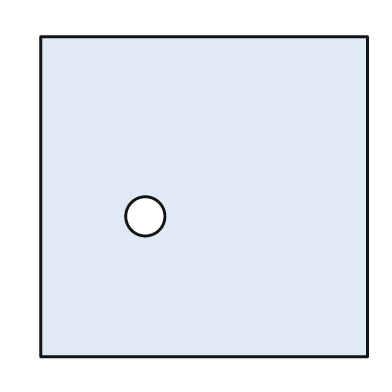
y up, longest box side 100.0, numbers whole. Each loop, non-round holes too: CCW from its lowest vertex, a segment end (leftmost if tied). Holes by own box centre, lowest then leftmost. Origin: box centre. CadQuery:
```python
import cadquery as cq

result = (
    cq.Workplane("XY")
    .moveTo(-50.0, -49.0)
    .lineTo(50.0, -49.0)
    .lineTo(50.0, 49.0)
    .lineTo(-50.0, 49.0)
    .close()
    .moveTo(-18.0, -6.0)
    .circle(6.0)
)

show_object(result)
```